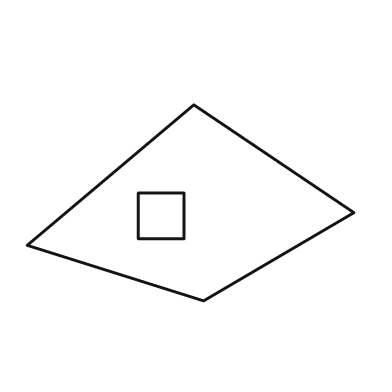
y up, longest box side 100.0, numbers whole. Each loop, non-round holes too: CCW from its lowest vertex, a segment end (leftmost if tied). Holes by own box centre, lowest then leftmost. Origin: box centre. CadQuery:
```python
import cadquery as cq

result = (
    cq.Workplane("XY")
    .moveTo(4.0, -30.0)
    .lineTo(50.0, -3.0)
    .lineTo(1.0, 30.0)
    .lineTo(-50.0, -13.0)
    .close()
    .moveTo(-16.0, -11.0)
    .lineTo(-2.0, -11.0)
    .lineTo(-2.0, 3.0)
    .lineTo(-16.0, 3.0)
    .close()
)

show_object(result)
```